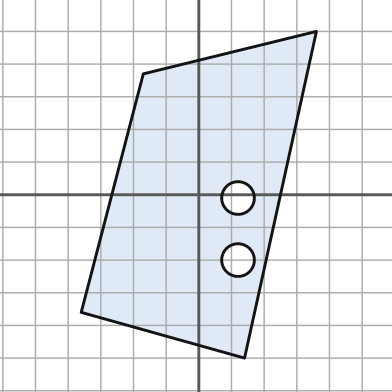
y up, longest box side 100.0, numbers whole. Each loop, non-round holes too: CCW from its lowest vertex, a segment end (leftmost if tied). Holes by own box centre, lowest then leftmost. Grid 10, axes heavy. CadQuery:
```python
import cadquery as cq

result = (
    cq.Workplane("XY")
    .moveTo(14.0, -50.0)
    .lineTo(36.0, 50.0)
    .lineTo(-17.0, 37.0)
    .lineTo(-36.0, -36.0)
    .close()
    .moveTo(12.0, -20.0)
    .circle(5.0)
    .moveTo(12.0, -1.0)
    .circle(5.0)
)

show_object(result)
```